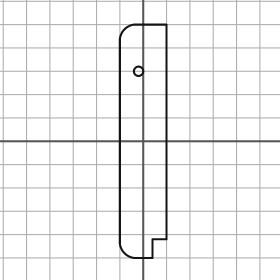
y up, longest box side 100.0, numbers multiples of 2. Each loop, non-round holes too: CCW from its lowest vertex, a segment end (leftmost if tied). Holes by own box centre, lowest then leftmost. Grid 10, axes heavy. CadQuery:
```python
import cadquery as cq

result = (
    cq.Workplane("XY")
    .moveTo(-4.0, -50.0)
    .lineTo(4.0, -50.0)
    .lineTo(4.0, -42.0)
    .lineTo(10.0, -42.0)
    .lineTo(10.0, 50.0)
    .lineTo(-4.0, 50.0)
    .threePointArc((-8.0, 48.0), (-10.0, 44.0))
    .lineTo(-10.0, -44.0)
    .threePointArc((-8.0, -48.0), (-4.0, -50.0))
    .close()
    .moveTo(-2.0, 30.0)
    .circle(2.0)
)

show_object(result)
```